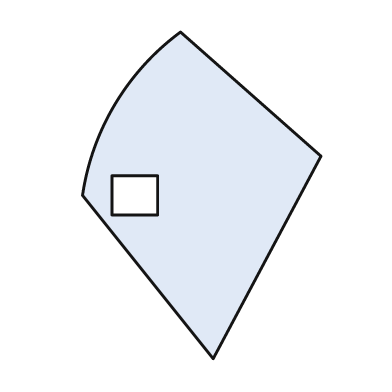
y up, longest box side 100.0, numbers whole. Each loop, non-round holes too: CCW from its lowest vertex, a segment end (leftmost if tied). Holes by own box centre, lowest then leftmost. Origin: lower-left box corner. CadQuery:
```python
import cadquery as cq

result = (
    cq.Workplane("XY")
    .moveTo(40.0, 0.0)
    .lineTo(73.0, 62.0)
    .lineTo(30.0, 100.0)
    .threePointArc((10.0, 78.0), (0.0, 50.0))
    .close()
    .moveTo(9.0, 44.0)
    .lineTo(23.0, 44.0)
    .lineTo(23.0, 56.0)
    .lineTo(9.0, 56.0)
    .close()
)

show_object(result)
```